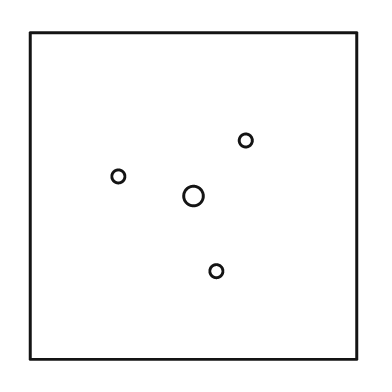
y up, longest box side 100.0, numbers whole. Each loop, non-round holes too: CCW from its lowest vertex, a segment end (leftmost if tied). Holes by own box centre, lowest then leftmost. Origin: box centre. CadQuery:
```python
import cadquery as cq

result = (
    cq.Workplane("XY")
    .moveTo(-50.0, -50.0)
    .lineTo(50.0, -50.0)
    .lineTo(50.0, 50.0)
    .lineTo(-50.0, 50.0)
    .close()
    .moveTo(7.0, -23.0)
    .circle(2.0)
    .moveTo(0.0, 0.0)
    .circle(3.0)
    .moveTo(-23.0, 6.0)
    .circle(2.0)
    .moveTo(16.0, 17.0)
    .circle(2.0)
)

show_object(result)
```